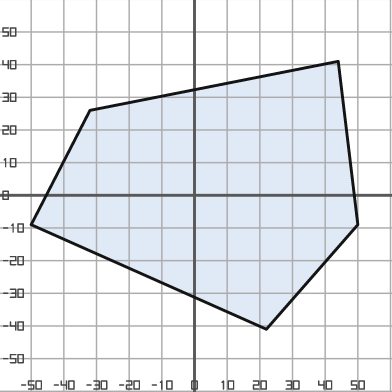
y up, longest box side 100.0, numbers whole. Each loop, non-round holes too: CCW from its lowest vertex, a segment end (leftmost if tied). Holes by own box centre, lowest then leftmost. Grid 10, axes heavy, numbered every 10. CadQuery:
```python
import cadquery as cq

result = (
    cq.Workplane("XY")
    .moveTo(22.0, -41.0)
    .lineTo(50.0, -9.0)
    .lineTo(44.0, 41.0)
    .lineTo(-32.0, 26.0)
    .lineTo(-50.0, -9.0)
    .close()
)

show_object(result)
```